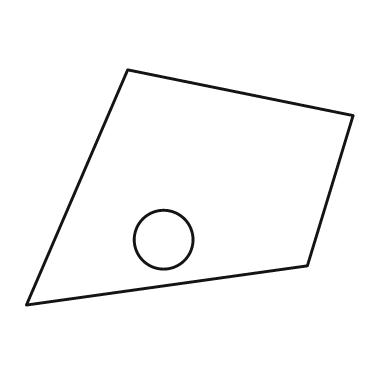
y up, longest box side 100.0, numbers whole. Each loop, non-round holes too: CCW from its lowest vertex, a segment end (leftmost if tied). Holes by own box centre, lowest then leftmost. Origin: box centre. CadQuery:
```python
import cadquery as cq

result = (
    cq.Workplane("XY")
    .moveTo(-50.0, -36.0)
    .lineTo(36.0, -24.0)
    .lineTo(50.0, 22.0)
    .lineTo(-19.0, 36.0)
    .close()
    .moveTo(-8.0, -16.0)
    .circle(9.0)
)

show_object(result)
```